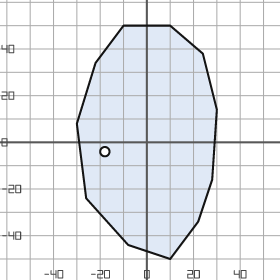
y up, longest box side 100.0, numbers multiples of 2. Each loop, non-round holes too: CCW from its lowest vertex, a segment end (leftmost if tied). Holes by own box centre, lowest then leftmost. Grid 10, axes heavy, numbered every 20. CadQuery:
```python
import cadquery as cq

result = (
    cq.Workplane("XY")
    .moveTo(10.0, -50.0)
    .lineTo(22.0, -34.0)
    .lineTo(28.0, -16.0)
    .lineTo(30.0, 14.0)
    .lineTo(24.0, 38.0)
    .lineTo(10.0, 50.0)
    .lineTo(-10.0, 50.0)
    .lineTo(-22.0, 34.0)
    .lineTo(-30.0, 8.0)
    .lineTo(-26.0, -24.0)
    .lineTo(-8.0, -44.0)
    .close()
    .moveTo(-18.0, -4.0)
    .circle(2.0)
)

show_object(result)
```